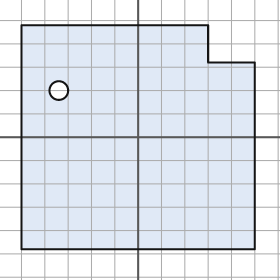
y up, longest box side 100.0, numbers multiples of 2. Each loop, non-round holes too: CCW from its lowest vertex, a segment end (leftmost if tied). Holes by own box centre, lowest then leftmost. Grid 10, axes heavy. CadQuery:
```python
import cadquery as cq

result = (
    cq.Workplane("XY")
    .moveTo(-50.0, -48.0)
    .lineTo(50.0, -48.0)
    .lineTo(50.0, 32.0)
    .lineTo(30.0, 32.0)
    .lineTo(30.0, 48.0)
    .lineTo(-50.0, 48.0)
    .close()
    .moveTo(-34.0, 20.0)
    .circle(4.0)
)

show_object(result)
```